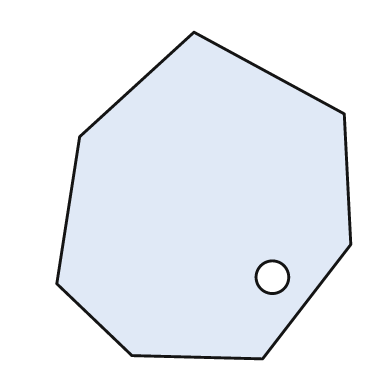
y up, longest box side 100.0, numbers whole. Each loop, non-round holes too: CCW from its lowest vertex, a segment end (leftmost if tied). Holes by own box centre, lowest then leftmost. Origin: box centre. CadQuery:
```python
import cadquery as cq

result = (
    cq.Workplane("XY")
    .moveTo(18.0, -50.0)
    .lineTo(45.0, -15.0)
    .lineTo(43.0, 25.0)
    .lineTo(-3.0, 50.0)
    .lineTo(-38.0, 18.0)
    .lineTo(-45.0, -27.0)
    .lineTo(-22.0, -49.0)
    .close()
    .moveTo(21.0, -25.0)
    .circle(5.0)
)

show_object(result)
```